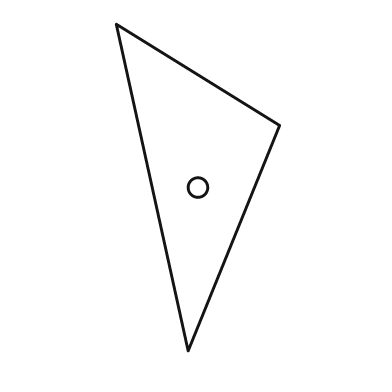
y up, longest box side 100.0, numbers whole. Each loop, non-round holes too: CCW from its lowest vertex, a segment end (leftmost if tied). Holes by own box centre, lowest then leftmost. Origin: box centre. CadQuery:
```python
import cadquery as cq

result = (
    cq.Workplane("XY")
    .moveTo(-3.0, -50.0)
    .lineTo(25.0, 19.0)
    .lineTo(-25.0, 50.0)
    .close()
    .moveTo(0.0, 0.0)
    .circle(3.0)
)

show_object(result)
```